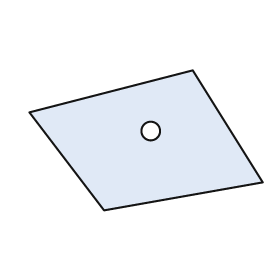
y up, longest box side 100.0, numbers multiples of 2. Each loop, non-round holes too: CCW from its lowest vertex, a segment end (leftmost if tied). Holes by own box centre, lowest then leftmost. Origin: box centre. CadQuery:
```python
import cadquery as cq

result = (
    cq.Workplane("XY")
    .moveTo(-18.0, -30.0)
    .lineTo(50.0, -18.0)
    .lineTo(20.0, 30.0)
    .lineTo(-50.0, 12.0)
    .close()
    .moveTo(2.0, 4.0)
    .circle(4.0)
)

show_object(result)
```